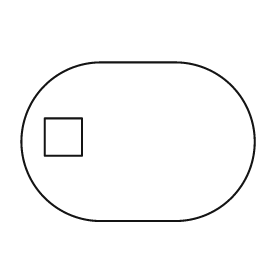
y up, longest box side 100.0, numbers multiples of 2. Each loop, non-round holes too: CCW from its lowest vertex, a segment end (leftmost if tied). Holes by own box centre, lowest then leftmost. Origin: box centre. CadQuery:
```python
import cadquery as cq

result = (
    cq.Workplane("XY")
    .moveTo(-16.0, -34.0)
    .lineTo(16.0, -34.0)
    .threePointArc((50.0, 0.0), (16.0, 34.0))
    .lineTo(-16.0, 34.0)
    .threePointArc((-50.0, 0.0), (-16.0, -34.0))
    .close()
    .moveTo(-40.0, -6.0)
    .lineTo(-24.0, -6.0)
    .lineTo(-24.0, 10.0)
    .lineTo(-40.0, 10.0)
    .close()
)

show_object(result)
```